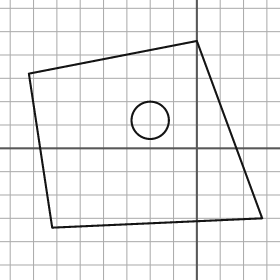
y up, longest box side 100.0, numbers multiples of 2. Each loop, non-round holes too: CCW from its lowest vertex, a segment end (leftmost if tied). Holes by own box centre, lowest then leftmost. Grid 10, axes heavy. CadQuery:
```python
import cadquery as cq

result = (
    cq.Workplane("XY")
    .moveTo(-62.0, -34.0)
    .lineTo(28.0, -30.0)
    .lineTo(0.0, 46.0)
    .lineTo(-72.0, 32.0)
    .close()
    .moveTo(-20.0, 12.0)
    .circle(8.0)
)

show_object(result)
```